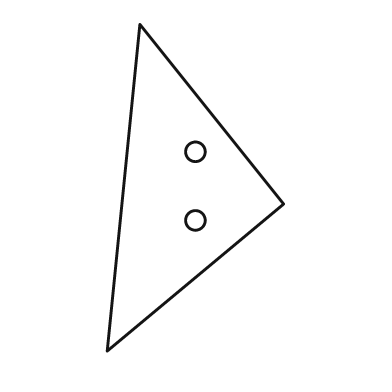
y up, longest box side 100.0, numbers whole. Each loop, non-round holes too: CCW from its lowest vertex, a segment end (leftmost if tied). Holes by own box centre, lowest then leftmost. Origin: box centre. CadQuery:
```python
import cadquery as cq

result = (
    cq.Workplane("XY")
    .moveTo(-27.0, -50.0)
    .lineTo(27.0, -5.0)
    .lineTo(-17.0, 50.0)
    .close()
    .moveTo(0.0, -10.0)
    .circle(3.0)
    .moveTo(0.0, 11.0)
    .circle(3.0)
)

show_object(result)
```